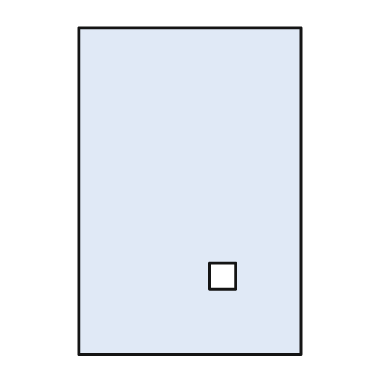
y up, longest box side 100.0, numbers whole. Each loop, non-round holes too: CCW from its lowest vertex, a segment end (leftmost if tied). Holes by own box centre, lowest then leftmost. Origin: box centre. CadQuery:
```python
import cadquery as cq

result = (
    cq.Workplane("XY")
    .moveTo(-34.0, -50.0)
    .lineTo(34.0, -50.0)
    .lineTo(34.0, 50.0)
    .lineTo(-34.0, 50.0)
    .close()
    .moveTo(6.0, -30.0)
    .lineTo(14.0, -30.0)
    .lineTo(14.0, -22.0)
    .lineTo(6.0, -22.0)
    .close()
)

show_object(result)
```